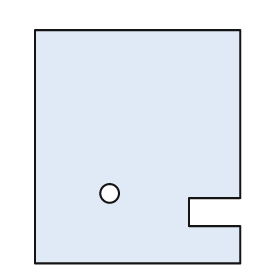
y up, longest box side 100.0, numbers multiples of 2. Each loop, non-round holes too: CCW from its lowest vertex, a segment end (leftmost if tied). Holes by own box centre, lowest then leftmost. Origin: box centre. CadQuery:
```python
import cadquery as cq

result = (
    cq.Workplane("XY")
    .moveTo(-44.0, -50.0)
    .lineTo(44.0, -50.0)
    .lineTo(44.0, -34.0)
    .lineTo(22.0, -34.0)
    .lineTo(22.0, -22.0)
    .lineTo(44.0, -22.0)
    .lineTo(44.0, 50.0)
    .lineTo(-44.0, 50.0)
    .close()
    .moveTo(-12.0, -20.0)
    .circle(4.0)
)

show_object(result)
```